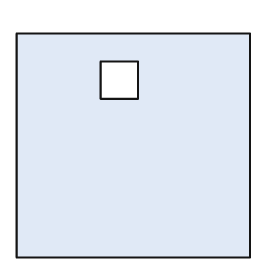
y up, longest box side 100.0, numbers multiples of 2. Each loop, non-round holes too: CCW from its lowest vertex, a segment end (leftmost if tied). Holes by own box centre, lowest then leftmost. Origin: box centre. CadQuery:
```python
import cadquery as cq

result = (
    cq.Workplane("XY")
    .moveTo(-50.0, -48.0)
    .lineTo(50.0, -48.0)
    .lineTo(50.0, 48.0)
    .lineTo(-50.0, 48.0)
    .close()
    .moveTo(-14.0, 20.0)
    .lineTo(2.0, 20.0)
    .lineTo(2.0, 36.0)
    .lineTo(-14.0, 36.0)
    .close()
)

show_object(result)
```